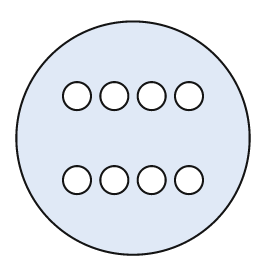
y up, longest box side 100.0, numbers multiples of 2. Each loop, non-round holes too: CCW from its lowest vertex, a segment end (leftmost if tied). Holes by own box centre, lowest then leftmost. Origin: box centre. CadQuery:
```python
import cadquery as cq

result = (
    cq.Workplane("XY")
    .moveTo(0.0, 0.0)
    .circle(50.0)
    .moveTo(-24.0, -18.0)
    .circle(6.0)
    .moveTo(-8.0, -18.0)
    .circle(6.0)
    .moveTo(8.0, -18.0)
    .circle(6.0)
    .moveTo(24.0, -18.0)
    .circle(6.0)
    .moveTo(-24.0, 18.0)
    .circle(6.0)
    .moveTo(-8.0, 18.0)
    .circle(6.0)
    .moveTo(8.0, 18.0)
    .circle(6.0)
    .moveTo(24.0, 18.0)
    .circle(6.0)
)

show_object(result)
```